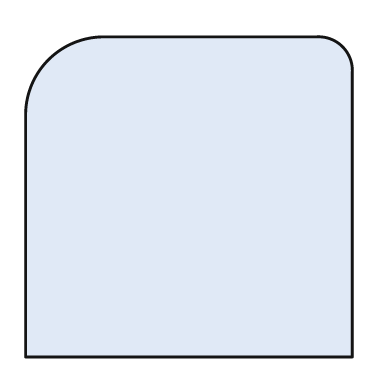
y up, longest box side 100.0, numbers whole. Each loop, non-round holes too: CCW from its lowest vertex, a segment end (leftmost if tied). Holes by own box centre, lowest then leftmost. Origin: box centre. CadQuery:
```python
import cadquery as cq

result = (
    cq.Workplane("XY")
    .moveTo(-50.0, -49.0)
    .lineTo(50.0, -49.0)
    .lineTo(50.0, 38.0)
    .threePointArc((47.0, 46.0), (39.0, 49.0))
    .lineTo(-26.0, 49.0)
    .threePointArc((-43.0, 42.0), (-50.0, 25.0))
    .close()
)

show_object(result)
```